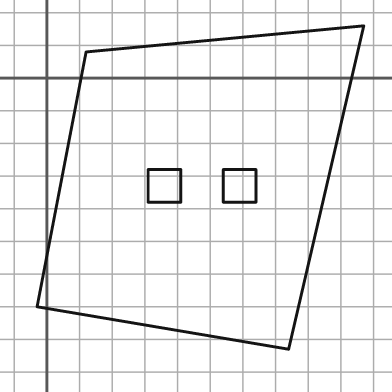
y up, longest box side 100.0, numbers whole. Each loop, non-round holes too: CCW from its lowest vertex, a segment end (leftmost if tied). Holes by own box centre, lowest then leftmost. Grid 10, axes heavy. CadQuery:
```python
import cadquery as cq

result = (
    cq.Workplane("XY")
    .moveTo(74.0, -83.0)
    .lineTo(97.0, 16.0)
    .lineTo(12.0, 8.0)
    .lineTo(-3.0, -70.0)
    .close()
    .moveTo(31.0, -38.0)
    .lineTo(41.0, -38.0)
    .lineTo(41.0, -28.0)
    .lineTo(31.0, -28.0)
    .close()
    .moveTo(54.0, -38.0)
    .lineTo(64.0, -38.0)
    .lineTo(64.0, -28.0)
    .lineTo(54.0, -28.0)
    .close()
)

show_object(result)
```